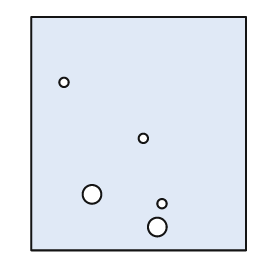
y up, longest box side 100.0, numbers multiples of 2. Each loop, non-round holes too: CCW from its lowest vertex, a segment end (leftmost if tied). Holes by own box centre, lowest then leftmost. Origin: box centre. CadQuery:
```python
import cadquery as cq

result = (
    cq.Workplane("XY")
    .moveTo(-46.0, -50.0)
    .lineTo(46.0, -50.0)
    .lineTo(46.0, 50.0)
    .lineTo(-46.0, 50.0)
    .close()
    .moveTo(8.0, -40.0)
    .circle(4.0)
    .moveTo(10.0, -30.0)
    .circle(2.0)
    .moveTo(-20.0, -26.0)
    .circle(4.0)
    .moveTo(2.0, -2.0)
    .circle(2.0)
    .moveTo(-32.0, 22.0)
    .circle(2.0)
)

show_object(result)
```